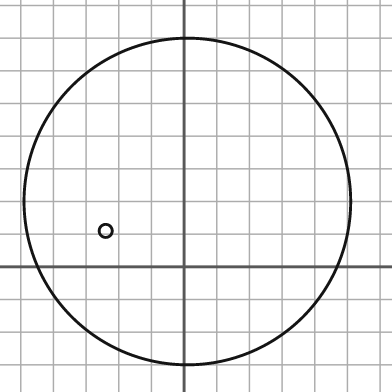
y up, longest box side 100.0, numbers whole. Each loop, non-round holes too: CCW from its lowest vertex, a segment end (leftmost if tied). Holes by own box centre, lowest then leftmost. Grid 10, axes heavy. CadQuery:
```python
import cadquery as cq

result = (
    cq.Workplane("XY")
    .moveTo(1.0, 20.0)
    .circle(50.0)
    .moveTo(-24.0, 11.0)
    .circle(2.0)
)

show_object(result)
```